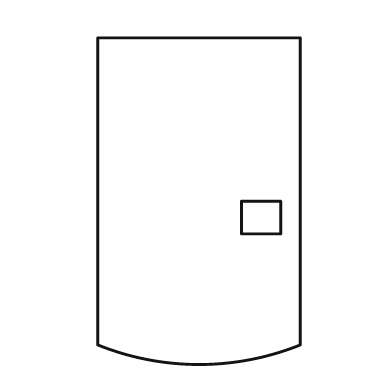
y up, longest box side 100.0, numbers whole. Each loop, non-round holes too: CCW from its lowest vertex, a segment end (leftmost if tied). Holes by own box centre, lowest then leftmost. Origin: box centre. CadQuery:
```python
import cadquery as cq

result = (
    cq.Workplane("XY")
    .moveTo(-31.0, -44.0)
    .threePointArc((0.0, -50.0), (31.0, -44.0))
    .lineTo(31.0, 50.0)
    .lineTo(-31.0, 50.0)
    .close()
    .moveTo(13.0, -10.0)
    .lineTo(25.0, -10.0)
    .lineTo(25.0, 0.0)
    .lineTo(13.0, 0.0)
    .close()
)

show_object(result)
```